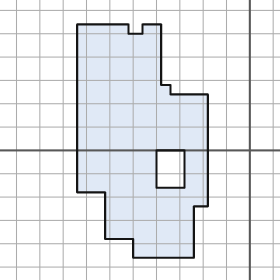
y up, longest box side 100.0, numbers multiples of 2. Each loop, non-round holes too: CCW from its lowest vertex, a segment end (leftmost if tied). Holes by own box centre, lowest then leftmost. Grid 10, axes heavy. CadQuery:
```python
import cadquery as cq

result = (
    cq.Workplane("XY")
    .moveTo(-50.0, -46.0)
    .lineTo(-24.0, -46.0)
    .lineTo(-24.0, -24.0)
    .lineTo(-18.0, -24.0)
    .lineTo(-18.0, 24.0)
    .lineTo(-34.0, 24.0)
    .lineTo(-34.0, 28.0)
    .lineTo(-38.0, 28.0)
    .lineTo(-38.0, 54.0)
    .lineTo(-46.0, 54.0)
    .lineTo(-46.0, 50.0)
    .lineTo(-52.0, 50.0)
    .lineTo(-52.0, 54.0)
    .lineTo(-74.0, 54.0)
    .lineTo(-74.0, -18.0)
    .lineTo(-62.0, -18.0)
    .lineTo(-62.0, -38.0)
    .lineTo(-50.0, -38.0)
    .close()
    .moveTo(-40.0, -16.0)
    .lineTo(-28.0, -16.0)
    .lineTo(-28.0, 0.0)
    .lineTo(-40.0, 0.0)
    .close()
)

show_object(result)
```